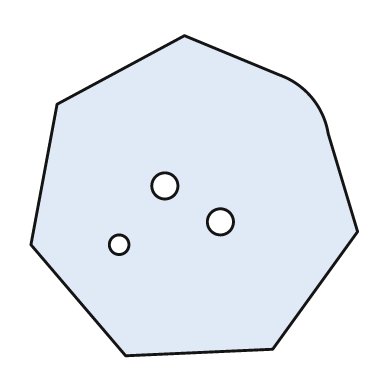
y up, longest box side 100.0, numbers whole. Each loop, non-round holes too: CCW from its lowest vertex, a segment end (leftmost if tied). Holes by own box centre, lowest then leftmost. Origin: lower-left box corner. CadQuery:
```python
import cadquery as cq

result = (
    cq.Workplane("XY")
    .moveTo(29.0, 0.0)
    .lineTo(74.0, 2.0)
    .lineTo(100.0, 38.0)
    .lineTo(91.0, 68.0)
    .threePointArc((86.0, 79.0), (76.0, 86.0))
    .lineTo(47.0, 98.0)
    .lineTo(8.0, 77.0)
    .lineTo(0.0, 34.0)
    .close()
    .moveTo(27.0, 34.0)
    .circle(3.0)
    .moveTo(58.0, 41.0)
    .circle(4.0)
    .moveTo(41.0, 52.0)
    .circle(4.0)
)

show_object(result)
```